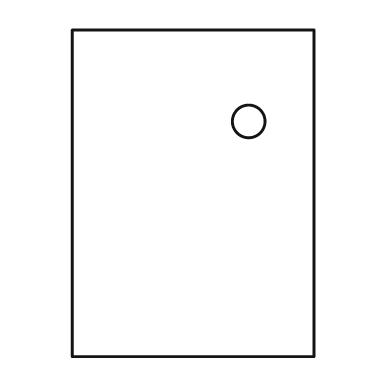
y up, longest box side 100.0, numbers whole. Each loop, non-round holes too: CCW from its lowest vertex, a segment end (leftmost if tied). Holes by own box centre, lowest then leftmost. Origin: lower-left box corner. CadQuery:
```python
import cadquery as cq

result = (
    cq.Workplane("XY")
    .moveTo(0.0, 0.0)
    .lineTo(74.0, 0.0)
    .lineTo(74.0, 100.0)
    .lineTo(0.0, 100.0)
    .close()
    .moveTo(54.0, 72.0)
    .circle(5.0)
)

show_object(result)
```